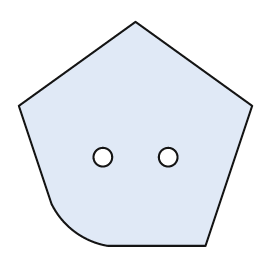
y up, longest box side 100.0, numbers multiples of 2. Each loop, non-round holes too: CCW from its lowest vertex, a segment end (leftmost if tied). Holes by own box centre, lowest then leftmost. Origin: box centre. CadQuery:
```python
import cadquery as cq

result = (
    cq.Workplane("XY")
    .moveTo(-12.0, -48.0)
    .lineTo(30.0, -48.0)
    .lineTo(50.0, 12.0)
    .lineTo(0.0, 48.0)
    .lineTo(-50.0, 12.0)
    .lineTo(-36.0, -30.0)
    .threePointArc((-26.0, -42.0), (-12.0, -48.0))
    .close()
    .moveTo(-14.0, -10.0)
    .circle(4.0)
    .moveTo(14.0, -10.0)
    .circle(4.0)
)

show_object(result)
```